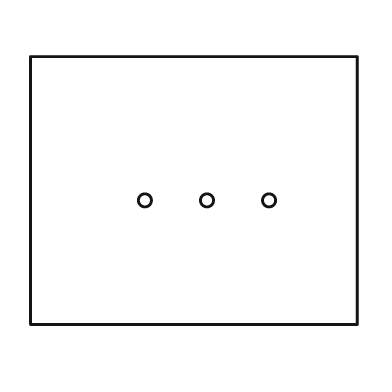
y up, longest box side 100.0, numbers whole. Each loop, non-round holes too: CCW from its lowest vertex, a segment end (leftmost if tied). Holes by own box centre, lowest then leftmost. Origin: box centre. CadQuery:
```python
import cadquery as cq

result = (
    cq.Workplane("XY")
    .moveTo(-50.0, -41.0)
    .lineTo(50.0, -41.0)
    .lineTo(50.0, 41.0)
    .lineTo(-50.0, 41.0)
    .close()
    .moveTo(-15.0, -3.0)
    .circle(2.0)
    .moveTo(4.0, -3.0)
    .circle(2.0)
    .moveTo(23.0, -3.0)
    .circle(2.0)
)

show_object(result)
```